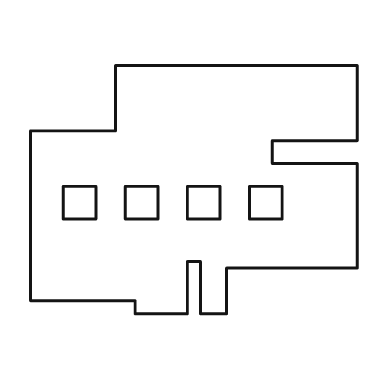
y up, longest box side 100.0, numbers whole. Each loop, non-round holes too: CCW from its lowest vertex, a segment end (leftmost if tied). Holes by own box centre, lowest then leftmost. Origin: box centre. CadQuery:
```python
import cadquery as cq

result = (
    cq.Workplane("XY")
    .moveTo(-18.0, -38.0)
    .lineTo(-2.0, -38.0)
    .lineTo(-2.0, -22.0)
    .lineTo(2.0, -22.0)
    .lineTo(2.0, -38.0)
    .lineTo(10.0, -38.0)
    .lineTo(10.0, -24.0)
    .lineTo(50.0, -24.0)
    .lineTo(50.0, 8.0)
    .lineTo(24.0, 8.0)
    .lineTo(24.0, 15.0)
    .lineTo(50.0, 15.0)
    .lineTo(50.0, 38.0)
    .lineTo(-24.0, 38.0)
    .lineTo(-24.0, 18.0)
    .lineTo(-50.0, 18.0)
    .lineTo(-50.0, -34.0)
    .lineTo(-18.0, -34.0)
    .close()
    .moveTo(-40.0, -9.0)
    .lineTo(-30.0, -9.0)
    .lineTo(-30.0, 1.0)
    .lineTo(-40.0, 1.0)
    .close()
    .moveTo(-21.0, -9.0)
    .lineTo(-11.0, -9.0)
    .lineTo(-11.0, 1.0)
    .lineTo(-21.0, 1.0)
    .close()
    .moveTo(-2.0, -9.0)
    .lineTo(8.0, -9.0)
    .lineTo(8.0, 1.0)
    .lineTo(-2.0, 1.0)
    .close()
    .moveTo(17.0, -9.0)
    .lineTo(27.0, -9.0)
    .lineTo(27.0, 1.0)
    .lineTo(17.0, 1.0)
    .close()
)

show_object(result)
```